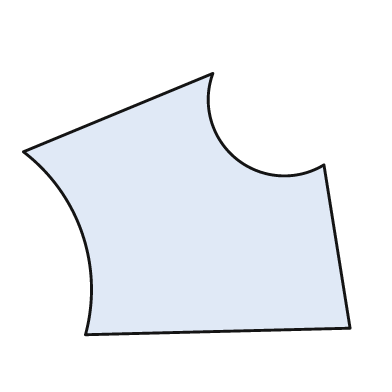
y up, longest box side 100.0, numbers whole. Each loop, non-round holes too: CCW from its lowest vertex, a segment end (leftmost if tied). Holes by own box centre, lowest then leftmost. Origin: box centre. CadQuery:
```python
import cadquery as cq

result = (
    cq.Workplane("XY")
    .moveTo(-31.0, -40.0)
    .lineTo(50.0, -38.0)
    .lineTo(42.0, 12.0)
    .threePointArc((15.0, 14.0), (8.0, 40.0))
    .lineTo(-50.0, 16.0)
    .threePointArc((-32.0, -9.0), (-31.0, -40.0))
    .close()
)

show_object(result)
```